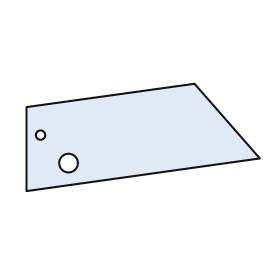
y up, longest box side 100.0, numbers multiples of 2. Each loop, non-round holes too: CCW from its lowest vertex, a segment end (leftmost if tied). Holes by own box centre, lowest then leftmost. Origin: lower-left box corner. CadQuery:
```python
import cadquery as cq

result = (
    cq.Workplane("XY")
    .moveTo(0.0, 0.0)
    .lineTo(100.0, 14.0)
    .lineTo(72.0, 46.0)
    .lineTo(0.0, 36.0)
    .close()
    .moveTo(18.0, 12.0)
    .circle(4.0)
    .moveTo(6.0, 24.0)
    .circle(2.0)
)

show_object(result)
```